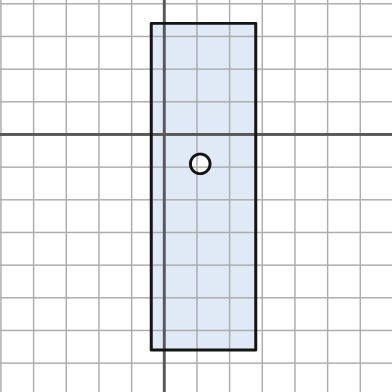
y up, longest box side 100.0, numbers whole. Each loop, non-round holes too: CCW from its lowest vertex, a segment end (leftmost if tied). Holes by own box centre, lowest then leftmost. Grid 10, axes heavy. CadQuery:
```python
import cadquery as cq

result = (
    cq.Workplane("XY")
    .moveTo(-4.0, -66.0)
    .lineTo(28.0, -66.0)
    .lineTo(28.0, 34.0)
    .lineTo(-4.0, 34.0)
    .close()
    .moveTo(11.0, -9.0)
    .circle(3.0)
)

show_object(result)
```